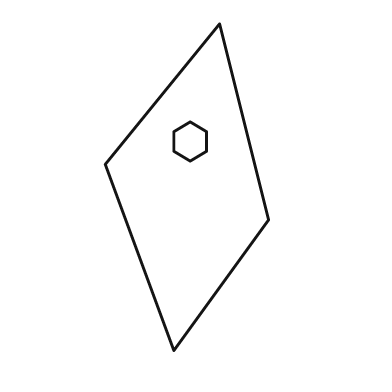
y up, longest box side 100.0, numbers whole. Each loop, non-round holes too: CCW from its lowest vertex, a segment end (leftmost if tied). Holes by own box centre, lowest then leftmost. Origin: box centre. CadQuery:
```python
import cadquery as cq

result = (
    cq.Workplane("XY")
    .moveTo(-4.0, -50.0)
    .lineTo(25.0, -10.0)
    .lineTo(10.0, 50.0)
    .lineTo(-25.0, 7.0)
    .close()
    .moveTo(1.0, 8.0)
    .lineTo(6.0, 11.0)
    .lineTo(6.0, 17.0)
    .lineTo(1.0, 20.0)
    .lineTo(-4.0, 17.0)
    .lineTo(-4.0, 11.0)
    .close()
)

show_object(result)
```